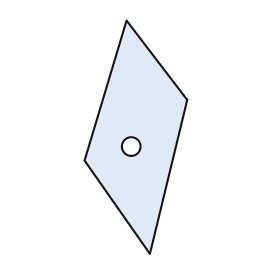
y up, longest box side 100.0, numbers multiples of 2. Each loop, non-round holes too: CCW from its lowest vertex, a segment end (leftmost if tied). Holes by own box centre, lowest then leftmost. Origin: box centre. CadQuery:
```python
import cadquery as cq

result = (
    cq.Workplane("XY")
    .moveTo(6.0, -50.0)
    .lineTo(22.0, 16.0)
    .lineTo(-4.0, 50.0)
    .lineTo(-22.0, -10.0)
    .close()
    .moveTo(-2.0, -4.0)
    .circle(4.0)
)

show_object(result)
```